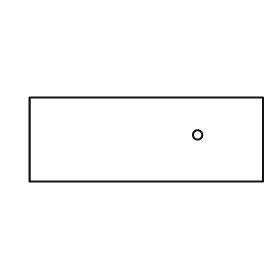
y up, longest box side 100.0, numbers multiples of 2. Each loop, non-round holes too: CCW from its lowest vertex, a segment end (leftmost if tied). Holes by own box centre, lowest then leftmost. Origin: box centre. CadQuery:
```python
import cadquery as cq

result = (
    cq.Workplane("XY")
    .moveTo(-50.0, -18.0)
    .lineTo(50.0, -18.0)
    .lineTo(50.0, 18.0)
    .lineTo(-50.0, 18.0)
    .close()
    .moveTo(22.0, 2.0)
    .circle(2.0)
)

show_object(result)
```